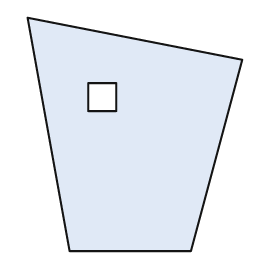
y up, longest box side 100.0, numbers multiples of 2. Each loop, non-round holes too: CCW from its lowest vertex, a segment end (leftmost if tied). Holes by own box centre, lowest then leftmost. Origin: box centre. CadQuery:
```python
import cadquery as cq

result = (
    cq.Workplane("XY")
    .moveTo(-28.0, -50.0)
    .lineTo(24.0, -50.0)
    .lineTo(46.0, 32.0)
    .lineTo(-46.0, 50.0)
    .close()
    .moveTo(-20.0, 10.0)
    .lineTo(-8.0, 10.0)
    .lineTo(-8.0, 22.0)
    .lineTo(-20.0, 22.0)
    .close()
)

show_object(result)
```